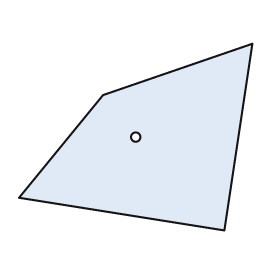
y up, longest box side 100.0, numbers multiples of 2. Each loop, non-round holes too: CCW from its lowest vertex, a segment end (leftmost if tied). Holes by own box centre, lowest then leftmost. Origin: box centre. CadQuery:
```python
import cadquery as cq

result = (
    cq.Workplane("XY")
    .moveTo(38.0, -40.0)
    .lineTo(50.0, 40.0)
    .lineTo(-14.0, 18.0)
    .lineTo(-50.0, -26.0)
    .close()
    .moveTo(0.0, 0.0)
    .circle(2.0)
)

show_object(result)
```